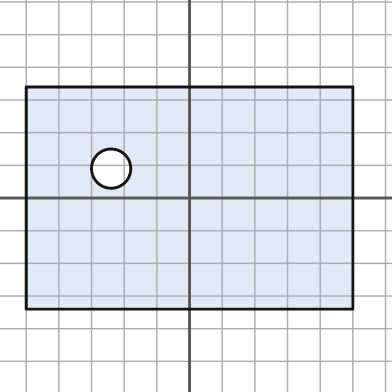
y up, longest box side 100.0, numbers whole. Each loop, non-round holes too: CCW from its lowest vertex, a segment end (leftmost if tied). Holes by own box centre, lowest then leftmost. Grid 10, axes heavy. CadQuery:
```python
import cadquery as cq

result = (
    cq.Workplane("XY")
    .moveTo(-50.0, -34.0)
    .lineTo(50.0, -34.0)
    .lineTo(50.0, 34.0)
    .lineTo(-50.0, 34.0)
    .close()
    .moveTo(-24.0, 9.0)
    .circle(6.0)
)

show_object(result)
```